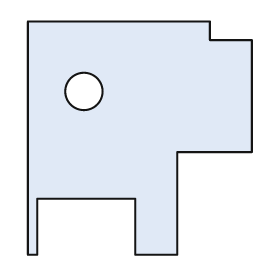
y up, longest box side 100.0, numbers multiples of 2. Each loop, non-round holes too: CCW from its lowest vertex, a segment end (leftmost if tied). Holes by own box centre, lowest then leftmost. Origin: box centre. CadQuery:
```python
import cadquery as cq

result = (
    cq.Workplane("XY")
    .moveTo(-48.0, -50.0)
    .lineTo(-44.0, -50.0)
    .lineTo(-44.0, -26.0)
    .lineTo(-2.0, -26.0)
    .lineTo(-2.0, -50.0)
    .lineTo(16.0, -50.0)
    .lineTo(16.0, -6.0)
    .lineTo(48.0, -6.0)
    .lineTo(48.0, 42.0)
    .lineTo(30.0, 42.0)
    .lineTo(30.0, 50.0)
    .lineTo(-48.0, 50.0)
    .close()
    .moveTo(-24.0, 20.0)
    .circle(8.0)
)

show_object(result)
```